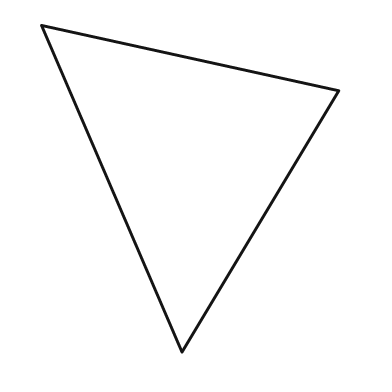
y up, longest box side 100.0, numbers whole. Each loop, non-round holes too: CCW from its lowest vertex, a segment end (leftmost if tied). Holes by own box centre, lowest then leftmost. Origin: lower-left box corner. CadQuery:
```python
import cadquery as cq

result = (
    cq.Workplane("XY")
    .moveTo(43.0, 0.0)
    .lineTo(91.0, 80.0)
    .lineTo(0.0, 100.0)
    .close()
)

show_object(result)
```